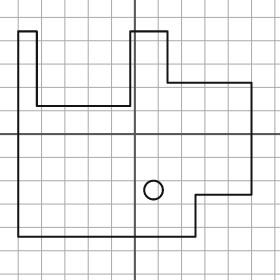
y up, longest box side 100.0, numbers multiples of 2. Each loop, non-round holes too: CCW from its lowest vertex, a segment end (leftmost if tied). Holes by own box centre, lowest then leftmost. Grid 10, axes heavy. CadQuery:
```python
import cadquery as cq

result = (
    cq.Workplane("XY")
    .moveTo(-50.0, -44.0)
    .lineTo(26.0, -44.0)
    .lineTo(26.0, -26.0)
    .lineTo(50.0, -26.0)
    .lineTo(50.0, 22.0)
    .lineTo(14.0, 22.0)
    .lineTo(14.0, 44.0)
    .lineTo(-2.0, 44.0)
    .lineTo(-2.0, 12.0)
    .lineTo(-42.0, 12.0)
    .lineTo(-42.0, 44.0)
    .lineTo(-50.0, 44.0)
    .close()
    .moveTo(8.0, -24.0)
    .circle(4.0)
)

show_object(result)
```